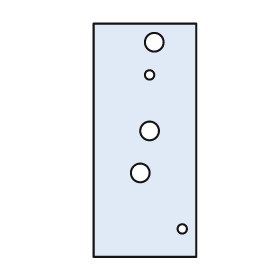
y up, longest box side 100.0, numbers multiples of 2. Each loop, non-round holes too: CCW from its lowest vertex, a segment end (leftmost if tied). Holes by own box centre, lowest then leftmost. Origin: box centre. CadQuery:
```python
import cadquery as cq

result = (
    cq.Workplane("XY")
    .moveTo(-22.0, -50.0)
    .lineTo(22.0, -50.0)
    .lineTo(22.0, 50.0)
    .lineTo(-22.0, 50.0)
    .close()
    .moveTo(16.0, -38.0)
    .circle(2.0)
    .moveTo(-2.0, -14.0)
    .circle(4.0)
    .moveTo(2.0, 4.0)
    .circle(4.0)
    .moveTo(2.0, 28.0)
    .circle(2.0)
    .moveTo(4.0, 42.0)
    .circle(4.0)
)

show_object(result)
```